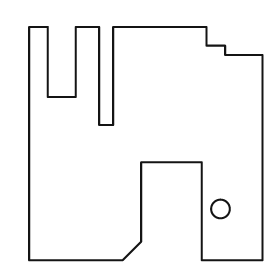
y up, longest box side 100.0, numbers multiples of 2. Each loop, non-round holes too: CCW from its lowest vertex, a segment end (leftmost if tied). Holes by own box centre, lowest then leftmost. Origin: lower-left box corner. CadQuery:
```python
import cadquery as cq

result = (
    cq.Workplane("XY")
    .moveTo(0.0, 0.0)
    .lineTo(40.0, 0.0)
    .lineTo(48.0, 8.0)
    .lineTo(48.0, 42.0)
    .lineTo(74.0, 42.0)
    .lineTo(74.0, 0.0)
    .lineTo(100.0, 0.0)
    .lineTo(100.0, 88.0)
    .lineTo(84.0, 88.0)
    .lineTo(84.0, 92.0)
    .lineTo(76.0, 92.0)
    .lineTo(76.0, 100.0)
    .lineTo(36.0, 100.0)
    .lineTo(36.0, 58.0)
    .lineTo(30.0, 58.0)
    .lineTo(30.0, 100.0)
    .lineTo(20.0, 100.0)
    .lineTo(20.0, 70.0)
    .lineTo(8.0, 70.0)
    .lineTo(8.0, 100.0)
    .lineTo(0.0, 100.0)
    .close()
    .moveTo(82.0, 22.0)
    .circle(4.0)
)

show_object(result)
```